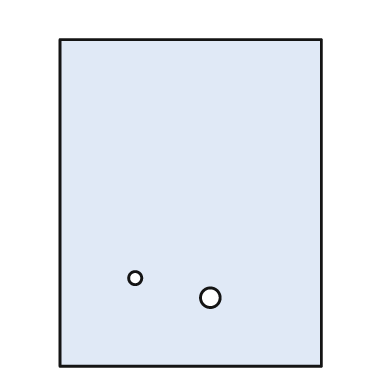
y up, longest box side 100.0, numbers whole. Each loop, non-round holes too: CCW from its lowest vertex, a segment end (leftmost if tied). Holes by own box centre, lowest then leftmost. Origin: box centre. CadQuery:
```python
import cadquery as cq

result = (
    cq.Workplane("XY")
    .moveTo(-40.0, -50.0)
    .lineTo(40.0, -50.0)
    .lineTo(40.0, 50.0)
    .lineTo(-40.0, 50.0)
    .close()
    .moveTo(6.0, -29.0)
    .circle(3.0)
    .moveTo(-17.0, -23.0)
    .circle(2.0)
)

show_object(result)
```